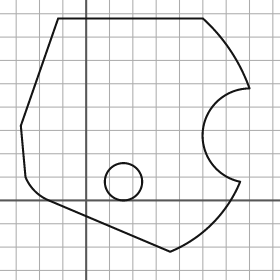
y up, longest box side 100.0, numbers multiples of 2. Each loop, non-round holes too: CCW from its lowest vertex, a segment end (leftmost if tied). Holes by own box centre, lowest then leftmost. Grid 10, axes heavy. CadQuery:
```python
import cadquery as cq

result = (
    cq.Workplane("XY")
    .moveTo(36.0, -22.0)
    .threePointArc((54.0, -10.0), (66.0, 8.0))
    .threePointArc((50.0, 30.0), (70.0, 48.0))
    .threePointArc((62.0, 64.0), (50.0, 78.0))
    .lineTo(-12.0, 78.0)
    .lineTo(-28.0, 32.0)
    .lineTo(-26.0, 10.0)
    .threePointArc((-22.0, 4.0), (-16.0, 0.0))
    .close()
    .moveTo(16.0, 8.0)
    .circle(8.0)
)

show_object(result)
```